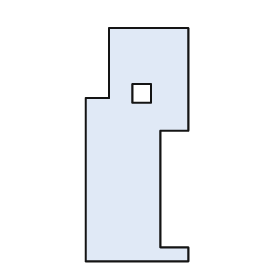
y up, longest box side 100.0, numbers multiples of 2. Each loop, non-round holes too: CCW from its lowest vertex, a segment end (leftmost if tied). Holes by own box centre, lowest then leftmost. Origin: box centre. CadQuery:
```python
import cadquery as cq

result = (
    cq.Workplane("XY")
    .moveTo(-22.0, -50.0)
    .lineTo(22.0, -50.0)
    .lineTo(22.0, -44.0)
    .lineTo(10.0, -44.0)
    .lineTo(10.0, 6.0)
    .lineTo(22.0, 6.0)
    .lineTo(22.0, 50.0)
    .lineTo(-12.0, 50.0)
    .lineTo(-12.0, 20.0)
    .lineTo(-22.0, 20.0)
    .close()
    .moveTo(-2.0, 18.0)
    .lineTo(6.0, 18.0)
    .lineTo(6.0, 26.0)
    .lineTo(-2.0, 26.0)
    .close()
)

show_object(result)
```